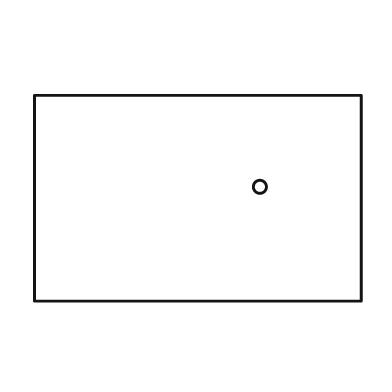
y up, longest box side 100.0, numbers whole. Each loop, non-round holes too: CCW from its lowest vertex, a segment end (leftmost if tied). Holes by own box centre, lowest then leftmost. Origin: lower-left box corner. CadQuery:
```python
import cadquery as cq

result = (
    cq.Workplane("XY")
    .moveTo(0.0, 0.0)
    .lineTo(100.0, 0.0)
    .lineTo(100.0, 63.0)
    .lineTo(0.0, 63.0)
    .close()
    .moveTo(69.0, 35.0)
    .circle(2.0)
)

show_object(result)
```